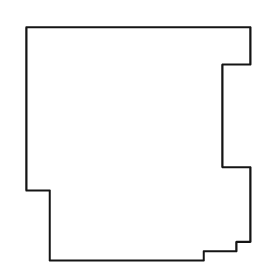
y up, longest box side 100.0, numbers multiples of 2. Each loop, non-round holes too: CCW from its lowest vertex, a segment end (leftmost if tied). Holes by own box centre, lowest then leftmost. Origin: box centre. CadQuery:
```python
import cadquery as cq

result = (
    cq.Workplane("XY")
    .moveTo(-38.0, -50.0)
    .lineTo(28.0, -50.0)
    .lineTo(28.0, -46.0)
    .lineTo(42.0, -46.0)
    .lineTo(42.0, -42.0)
    .lineTo(48.0, -42.0)
    .lineTo(48.0, -10.0)
    .lineTo(36.0, -10.0)
    .lineTo(36.0, 34.0)
    .lineTo(48.0, 34.0)
    .lineTo(48.0, 50.0)
    .lineTo(-48.0, 50.0)
    .lineTo(-48.0, -20.0)
    .lineTo(-38.0, -20.0)
    .close()
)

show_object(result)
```